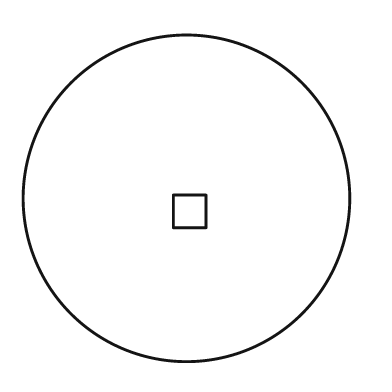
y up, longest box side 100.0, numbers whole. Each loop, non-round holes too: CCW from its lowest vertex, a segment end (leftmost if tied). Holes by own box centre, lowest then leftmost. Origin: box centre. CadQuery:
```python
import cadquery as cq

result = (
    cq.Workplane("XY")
    .moveTo(0.0, 0.0)
    .circle(50.0)
    .moveTo(-4.0, -9.0)
    .lineTo(6.0, -9.0)
    .lineTo(6.0, 1.0)
    .lineTo(-4.0, 1.0)
    .close()
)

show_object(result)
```